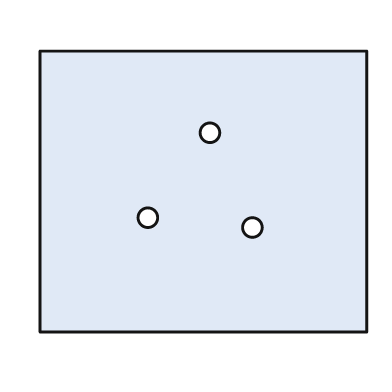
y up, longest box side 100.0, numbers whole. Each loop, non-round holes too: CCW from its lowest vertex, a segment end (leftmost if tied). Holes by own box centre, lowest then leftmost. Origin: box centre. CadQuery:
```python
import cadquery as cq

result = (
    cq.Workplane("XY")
    .moveTo(-50.0, -43.0)
    .lineTo(50.0, -43.0)
    .lineTo(50.0, 43.0)
    .lineTo(-50.0, 43.0)
    .close()
    .moveTo(15.0, -11.0)
    .circle(3.0)
    .moveTo(-17.0, -8.0)
    .circle(3.0)
    .moveTo(2.0, 18.0)
    .circle(3.0)
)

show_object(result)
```